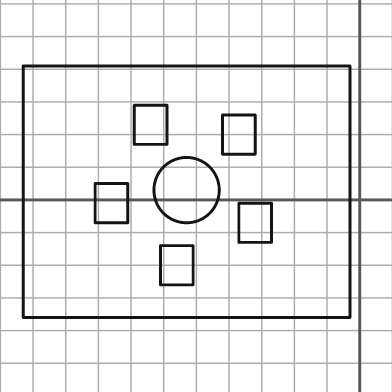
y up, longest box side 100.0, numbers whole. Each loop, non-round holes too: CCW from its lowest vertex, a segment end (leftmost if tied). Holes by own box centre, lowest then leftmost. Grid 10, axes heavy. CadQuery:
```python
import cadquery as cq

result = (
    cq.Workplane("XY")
    .moveTo(-103.0, -36.0)
    .lineTo(-3.0, -36.0)
    .lineTo(-3.0, 41.0)
    .lineTo(-103.0, 41.0)
    .close()
    .moveTo(-61.0, -26.0)
    .lineTo(-51.0, -26.0)
    .lineTo(-51.0, -14.0)
    .lineTo(-61.0, -14.0)
    .close()
    .moveTo(-37.0, -13.0)
    .lineTo(-27.0, -13.0)
    .lineTo(-27.0, -1.0)
    .lineTo(-37.0, -1.0)
    .close()
    .moveTo(-81.0, -7.0)
    .lineTo(-71.0, -7.0)
    .lineTo(-71.0, 5.0)
    .lineTo(-81.0, 5.0)
    .close()
    .moveTo(-53.0, 3.0)
    .circle(10.0)
    .moveTo(-42.0, 14.0)
    .lineTo(-32.0, 14.0)
    .lineTo(-32.0, 26.0)
    .lineTo(-42.0, 26.0)
    .close()
    .moveTo(-69.0, 17.0)
    .lineTo(-59.0, 17.0)
    .lineTo(-59.0, 29.0)
    .lineTo(-69.0, 29.0)
    .close()
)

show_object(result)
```